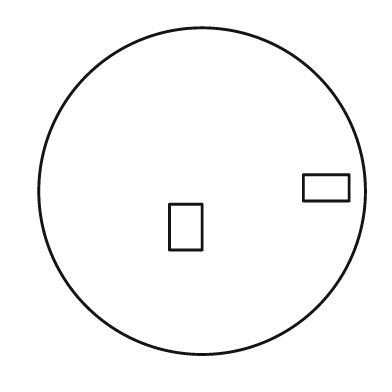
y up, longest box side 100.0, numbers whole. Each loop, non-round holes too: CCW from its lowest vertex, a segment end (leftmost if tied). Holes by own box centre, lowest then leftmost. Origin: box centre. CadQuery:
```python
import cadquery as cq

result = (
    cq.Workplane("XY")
    .moveTo(0.0, 0.0)
    .circle(50.0)
    .moveTo(-10.0, -18.0)
    .lineTo(0.0, -18.0)
    .lineTo(0.0, -4.0)
    .lineTo(-10.0, -4.0)
    .close()
    .moveTo(31.0, -3.0)
    .lineTo(45.0, -3.0)
    .lineTo(45.0, 5.0)
    .lineTo(31.0, 5.0)
    .close()
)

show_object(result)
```